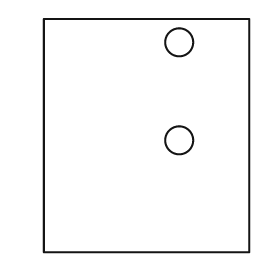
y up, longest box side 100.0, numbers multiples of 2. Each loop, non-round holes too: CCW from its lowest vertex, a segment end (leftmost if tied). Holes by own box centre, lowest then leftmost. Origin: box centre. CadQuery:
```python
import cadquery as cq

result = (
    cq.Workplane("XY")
    .moveTo(-44.0, -50.0)
    .lineTo(44.0, -50.0)
    .lineTo(44.0, 50.0)
    .lineTo(-44.0, 50.0)
    .close()
    .moveTo(14.0, -2.0)
    .circle(6.0)
    .moveTo(14.0, 40.0)
    .circle(6.0)
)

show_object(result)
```